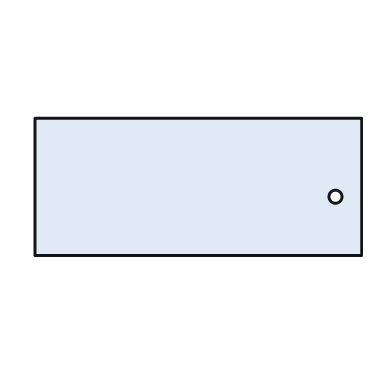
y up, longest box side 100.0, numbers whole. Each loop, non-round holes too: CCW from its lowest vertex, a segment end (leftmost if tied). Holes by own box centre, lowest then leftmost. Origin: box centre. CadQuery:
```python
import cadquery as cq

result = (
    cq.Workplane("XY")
    .moveTo(-50.0, -21.0)
    .lineTo(50.0, -21.0)
    .lineTo(50.0, 21.0)
    .lineTo(-50.0, 21.0)
    .close()
    .moveTo(42.0, -3.0)
    .circle(2.0)
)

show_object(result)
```